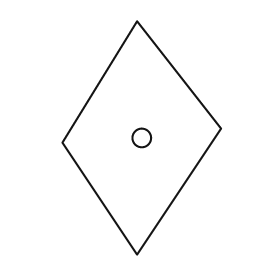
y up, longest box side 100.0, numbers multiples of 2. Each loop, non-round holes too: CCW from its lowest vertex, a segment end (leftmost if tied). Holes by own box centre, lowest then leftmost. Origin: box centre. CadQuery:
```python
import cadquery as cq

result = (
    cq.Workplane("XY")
    .moveTo(-2.0, -50.0)
    .lineTo(34.0, 4.0)
    .lineTo(-2.0, 50.0)
    .lineTo(-34.0, -2.0)
    .close()
    .moveTo(0.0, 0.0)
    .circle(4.0)
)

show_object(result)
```